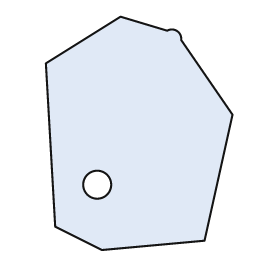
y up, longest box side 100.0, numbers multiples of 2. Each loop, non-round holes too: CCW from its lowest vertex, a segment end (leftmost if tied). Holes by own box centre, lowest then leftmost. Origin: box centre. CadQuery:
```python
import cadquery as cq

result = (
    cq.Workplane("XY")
    .moveTo(-16.0, -50.0)
    .lineTo(28.0, -46.0)
    .lineTo(40.0, 8.0)
    .lineTo(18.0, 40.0)
    .threePointArc((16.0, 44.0), (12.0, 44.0))
    .lineTo(-8.0, 50.0)
    .lineTo(-40.0, 30.0)
    .lineTo(-36.0, -40.0)
    .close()
    .moveTo(-18.0, -22.0)
    .circle(6.0)
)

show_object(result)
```